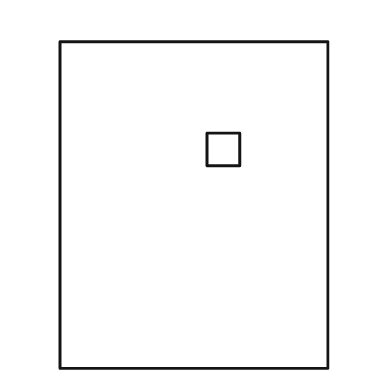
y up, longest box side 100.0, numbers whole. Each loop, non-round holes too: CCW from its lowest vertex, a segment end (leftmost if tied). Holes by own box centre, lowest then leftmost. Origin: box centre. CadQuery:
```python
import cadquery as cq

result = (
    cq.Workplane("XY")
    .moveTo(-41.0, -50.0)
    .lineTo(41.0, -50.0)
    .lineTo(41.0, 50.0)
    .lineTo(-41.0, 50.0)
    .close()
    .moveTo(4.0, 12.0)
    .lineTo(14.0, 12.0)
    .lineTo(14.0, 22.0)
    .lineTo(4.0, 22.0)
    .close()
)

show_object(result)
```